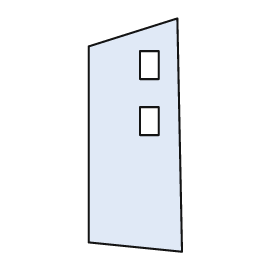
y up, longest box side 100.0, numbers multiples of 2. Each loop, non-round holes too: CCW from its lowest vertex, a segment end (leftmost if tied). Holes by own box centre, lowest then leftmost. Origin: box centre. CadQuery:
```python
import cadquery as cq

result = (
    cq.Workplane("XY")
    .moveTo(20.0, -50.0)
    .lineTo(18.0, 50.0)
    .lineTo(-20.0, 38.0)
    .lineTo(-20.0, -46.0)
    .close()
    .moveTo(2.0, 0.0)
    .lineTo(10.0, 0.0)
    .lineTo(10.0, 12.0)
    .lineTo(2.0, 12.0)
    .close()
    .moveTo(2.0, 24.0)
    .lineTo(10.0, 24.0)
    .lineTo(10.0, 36.0)
    .lineTo(2.0, 36.0)
    .close()
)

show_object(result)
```